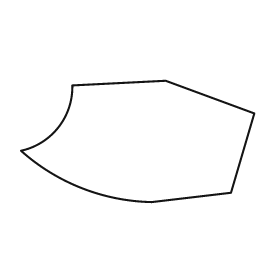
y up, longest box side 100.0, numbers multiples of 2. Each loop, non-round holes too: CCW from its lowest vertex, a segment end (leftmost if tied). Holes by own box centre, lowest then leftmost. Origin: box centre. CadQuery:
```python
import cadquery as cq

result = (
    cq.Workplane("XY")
    .moveTo(6.0, -26.0)
    .lineTo(40.0, -22.0)
    .lineTo(50.0, 12.0)
    .lineTo(12.0, 26.0)
    .lineTo(-28.0, 24.0)
    .threePointArc((-34.0, 6.0), (-50.0, -4.0))
    .threePointArc((-24.0, -20.0), (6.0, -26.0))
    .close()
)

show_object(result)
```